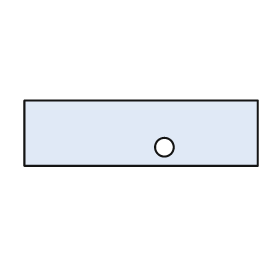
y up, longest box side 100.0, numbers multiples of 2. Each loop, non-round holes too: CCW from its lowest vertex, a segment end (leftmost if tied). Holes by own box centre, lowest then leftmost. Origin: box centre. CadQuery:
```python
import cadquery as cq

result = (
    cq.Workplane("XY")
    .moveTo(-50.0, -14.0)
    .lineTo(50.0, -14.0)
    .lineTo(50.0, 14.0)
    .lineTo(-50.0, 14.0)
    .close()
    .moveTo(10.0, -6.0)
    .circle(4.0)
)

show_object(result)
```